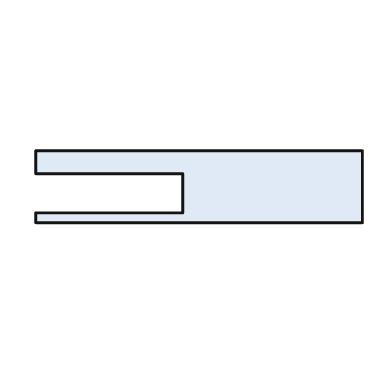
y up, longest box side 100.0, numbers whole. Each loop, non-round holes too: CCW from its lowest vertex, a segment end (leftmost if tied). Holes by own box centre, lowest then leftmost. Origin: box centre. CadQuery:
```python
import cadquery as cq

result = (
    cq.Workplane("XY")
    .moveTo(-50.0, -11.0)
    .lineTo(50.0, -11.0)
    .lineTo(50.0, 11.0)
    .lineTo(-50.0, 11.0)
    .lineTo(-50.0, 4.0)
    .lineTo(-5.0, 4.0)
    .lineTo(-5.0, -8.0)
    .lineTo(-50.0, -8.0)
    .close()
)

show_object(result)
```